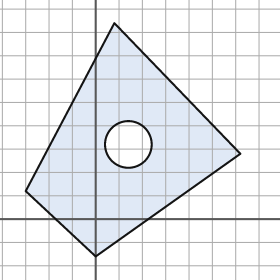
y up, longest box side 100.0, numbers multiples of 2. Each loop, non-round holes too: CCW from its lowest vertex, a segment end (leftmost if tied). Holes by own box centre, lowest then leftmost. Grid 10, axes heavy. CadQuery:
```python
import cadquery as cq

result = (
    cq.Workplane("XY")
    .moveTo(0.0, -16.0)
    .lineTo(62.0, 28.0)
    .lineTo(8.0, 84.0)
    .lineTo(-30.0, 12.0)
    .close()
    .moveTo(14.0, 32.0)
    .circle(10.0)
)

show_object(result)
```